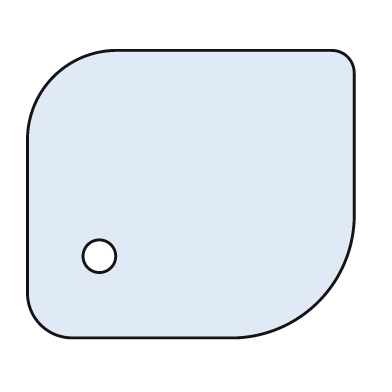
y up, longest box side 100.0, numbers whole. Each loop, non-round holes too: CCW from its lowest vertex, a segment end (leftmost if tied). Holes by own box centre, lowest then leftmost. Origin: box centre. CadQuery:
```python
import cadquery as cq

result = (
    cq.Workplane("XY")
    .moveTo(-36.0, -44.0)
    .lineTo(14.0, -44.0)
    .threePointArc((39.0, -33.0), (50.0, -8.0))
    .lineTo(50.0, 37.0)
    .threePointArc((48.0, 42.0), (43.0, 44.0))
    .lineTo(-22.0, 44.0)
    .threePointArc((-42.0, 36.0), (-50.0, 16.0))
    .lineTo(-50.0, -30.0)
    .threePointArc((-46.0, -40.0), (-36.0, -44.0))
    .close()
    .moveTo(-28.0, -19.0)
    .circle(5.0)
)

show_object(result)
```